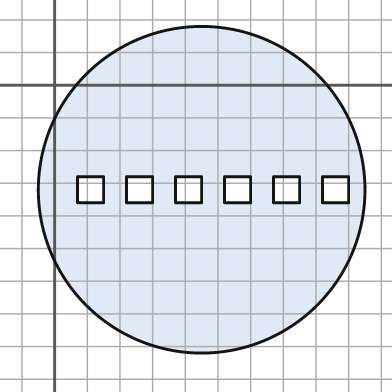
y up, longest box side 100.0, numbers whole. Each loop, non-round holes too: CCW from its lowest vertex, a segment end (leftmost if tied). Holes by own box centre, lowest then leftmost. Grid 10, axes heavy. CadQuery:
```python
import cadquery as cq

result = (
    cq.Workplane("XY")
    .moveTo(45.0, -32.0)
    .circle(50.0)
    .moveTo(7.0, -36.0)
    .lineTo(15.0, -36.0)
    .lineTo(15.0, -28.0)
    .lineTo(7.0, -28.0)
    .close()
    .moveTo(22.0, -36.0)
    .lineTo(30.0, -36.0)
    .lineTo(30.0, -28.0)
    .lineTo(22.0, -28.0)
    .close()
    .moveTo(37.0, -36.0)
    .lineTo(45.0, -36.0)
    .lineTo(45.0, -28.0)
    .lineTo(37.0, -28.0)
    .close()
    .moveTo(52.0, -36.0)
    .lineTo(60.0, -36.0)
    .lineTo(60.0, -28.0)
    .lineTo(52.0, -28.0)
    .close()
    .moveTo(67.0, -36.0)
    .lineTo(75.0, -36.0)
    .lineTo(75.0, -28.0)
    .lineTo(67.0, -28.0)
    .close()
    .moveTo(82.0, -36.0)
    .lineTo(90.0, -36.0)
    .lineTo(90.0, -28.0)
    .lineTo(82.0, -28.0)
    .close()
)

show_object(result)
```